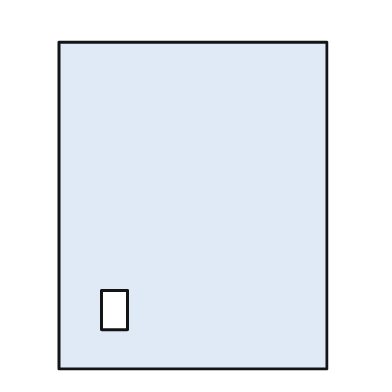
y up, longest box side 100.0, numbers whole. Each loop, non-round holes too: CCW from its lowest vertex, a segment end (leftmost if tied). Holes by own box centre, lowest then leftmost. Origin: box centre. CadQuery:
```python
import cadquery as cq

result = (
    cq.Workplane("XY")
    .moveTo(-41.0, -50.0)
    .lineTo(41.0, -50.0)
    .lineTo(41.0, 50.0)
    .lineTo(-41.0, 50.0)
    .close()
    .moveTo(-28.0, -38.0)
    .lineTo(-20.0, -38.0)
    .lineTo(-20.0, -26.0)
    .lineTo(-28.0, -26.0)
    .close()
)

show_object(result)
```